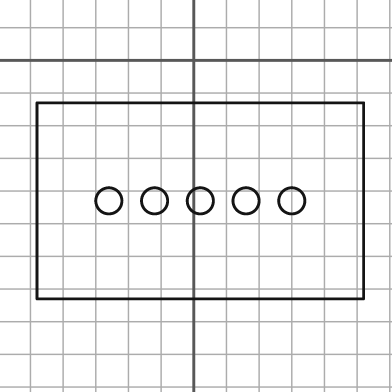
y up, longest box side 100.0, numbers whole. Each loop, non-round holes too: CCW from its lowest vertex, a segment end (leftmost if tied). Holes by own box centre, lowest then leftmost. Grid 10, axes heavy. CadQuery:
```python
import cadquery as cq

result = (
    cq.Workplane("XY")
    .moveTo(-48.0, -73.0)
    .lineTo(52.0, -73.0)
    .lineTo(52.0, -13.0)
    .lineTo(-48.0, -13.0)
    .close()
    .moveTo(-26.0, -43.0)
    .circle(4.0)
    .moveTo(-12.0, -43.0)
    .circle(4.0)
    .moveTo(2.0, -43.0)
    .circle(4.0)
    .moveTo(16.0, -43.0)
    .circle(4.0)
    .moveTo(30.0, -43.0)
    .circle(4.0)
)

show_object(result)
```